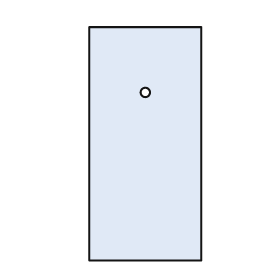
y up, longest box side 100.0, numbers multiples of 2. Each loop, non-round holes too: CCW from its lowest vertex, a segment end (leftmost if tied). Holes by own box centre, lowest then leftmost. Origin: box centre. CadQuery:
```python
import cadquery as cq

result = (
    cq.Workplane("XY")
    .moveTo(-24.0, -50.0)
    .lineTo(24.0, -50.0)
    .lineTo(24.0, 50.0)
    .lineTo(-24.0, 50.0)
    .close()
    .moveTo(0.0, 22.0)
    .circle(2.0)
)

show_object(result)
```